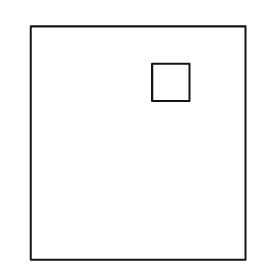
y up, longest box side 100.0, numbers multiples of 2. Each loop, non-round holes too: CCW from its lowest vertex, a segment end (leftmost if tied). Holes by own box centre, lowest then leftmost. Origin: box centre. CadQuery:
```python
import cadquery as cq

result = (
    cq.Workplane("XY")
    .moveTo(-46.0, -50.0)
    .lineTo(46.0, -50.0)
    .lineTo(46.0, 50.0)
    .lineTo(-46.0, 50.0)
    .close()
    .moveTo(6.0, 18.0)
    .lineTo(22.0, 18.0)
    .lineTo(22.0, 34.0)
    .lineTo(6.0, 34.0)
    .close()
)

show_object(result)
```